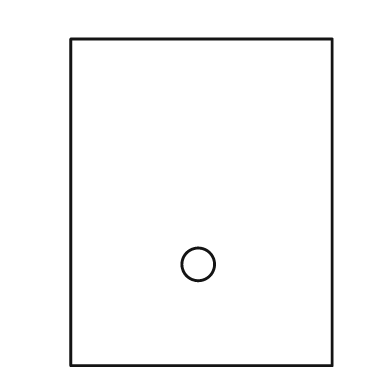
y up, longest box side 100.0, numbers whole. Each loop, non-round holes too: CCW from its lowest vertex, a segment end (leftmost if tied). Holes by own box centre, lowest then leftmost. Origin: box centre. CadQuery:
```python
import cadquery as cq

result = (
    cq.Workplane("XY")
    .moveTo(-40.0, -50.0)
    .lineTo(40.0, -50.0)
    .lineTo(40.0, 50.0)
    .lineTo(-40.0, 50.0)
    .close()
    .moveTo(-1.0, -19.0)
    .circle(5.0)
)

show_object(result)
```